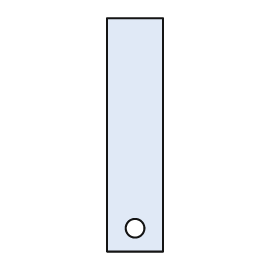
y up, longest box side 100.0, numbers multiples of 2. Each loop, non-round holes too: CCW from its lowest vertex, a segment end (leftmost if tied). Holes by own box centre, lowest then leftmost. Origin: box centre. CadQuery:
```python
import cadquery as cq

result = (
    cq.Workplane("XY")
    .moveTo(-12.0, -50.0)
    .lineTo(12.0, -50.0)
    .lineTo(12.0, 50.0)
    .lineTo(-12.0, 50.0)
    .close()
    .moveTo(0.0, -40.0)
    .circle(4.0)
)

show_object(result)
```